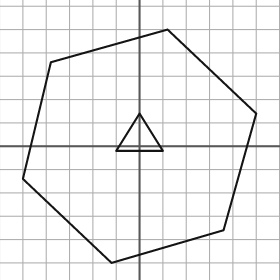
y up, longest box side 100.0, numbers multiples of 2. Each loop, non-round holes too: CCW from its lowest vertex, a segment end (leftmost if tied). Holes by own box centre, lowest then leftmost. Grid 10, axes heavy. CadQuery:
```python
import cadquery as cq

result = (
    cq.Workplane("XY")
    .moveTo(-12.0, -50.0)
    .lineTo(36.0, -36.0)
    .lineTo(50.0, 14.0)
    .lineTo(12.0, 50.0)
    .lineTo(-38.0, 36.0)
    .lineTo(-50.0, -14.0)
    .close()
    .moveTo(-10.0, -2.0)
    .lineTo(10.0, -2.0)
    .lineTo(0.0, 14.0)
    .close()
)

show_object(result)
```